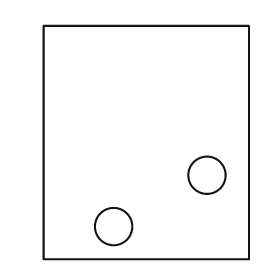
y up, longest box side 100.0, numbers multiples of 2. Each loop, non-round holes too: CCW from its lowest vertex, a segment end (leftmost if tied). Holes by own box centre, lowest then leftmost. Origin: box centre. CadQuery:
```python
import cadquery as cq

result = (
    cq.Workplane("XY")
    .moveTo(-44.0, -50.0)
    .lineTo(44.0, -50.0)
    .lineTo(44.0, 50.0)
    .lineTo(-44.0, 50.0)
    .close()
    .moveTo(-14.0, -36.0)
    .circle(8.0)
    .moveTo(26.0, -14.0)
    .circle(8.0)
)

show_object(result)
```